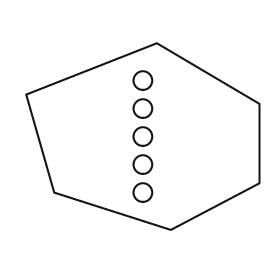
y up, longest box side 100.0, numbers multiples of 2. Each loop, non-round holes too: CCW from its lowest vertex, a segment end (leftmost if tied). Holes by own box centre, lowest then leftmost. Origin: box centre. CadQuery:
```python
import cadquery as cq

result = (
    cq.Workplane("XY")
    .moveTo(12.0, -40.0)
    .lineTo(50.0, -20.0)
    .lineTo(50.0, 14.0)
    .lineTo(6.0, 40.0)
    .lineTo(-50.0, 18.0)
    .lineTo(-38.0, -24.0)
    .close()
    .moveTo(0.0, -24.0)
    .circle(4.0)
    .moveTo(0.0, -12.0)
    .circle(4.0)
    .moveTo(0.0, 0.0)
    .circle(4.0)
    .moveTo(0.0, 12.0)
    .circle(4.0)
    .moveTo(0.0, 24.0)
    .circle(4.0)
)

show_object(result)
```